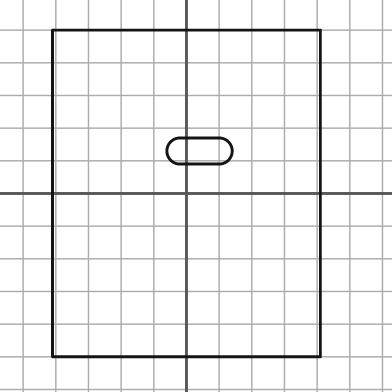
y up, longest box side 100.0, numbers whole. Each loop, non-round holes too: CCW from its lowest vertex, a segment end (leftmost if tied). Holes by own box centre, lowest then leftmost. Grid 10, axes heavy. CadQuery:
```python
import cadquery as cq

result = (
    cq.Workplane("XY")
    .moveTo(-41.0, -50.0)
    .lineTo(41.0, -50.0)
    .lineTo(41.0, 50.0)
    .lineTo(-41.0, 50.0)
    .close()
    .moveTo(-2.0, 9.0)
    .lineTo(10.0, 9.0)
    .threePointArc((14.0, 13.0), (10.0, 17.0))
    .lineTo(-2.0, 17.0)
    .threePointArc((-6.0, 13.0), (-2.0, 9.0))
    .close()
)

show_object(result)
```